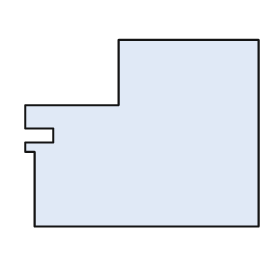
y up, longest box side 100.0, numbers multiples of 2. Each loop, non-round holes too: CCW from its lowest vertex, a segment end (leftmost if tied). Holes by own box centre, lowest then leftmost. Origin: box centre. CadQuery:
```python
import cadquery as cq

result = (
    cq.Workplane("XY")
    .moveTo(-46.0, -40.0)
    .lineTo(50.0, -40.0)
    .lineTo(50.0, 40.0)
    .lineTo(-10.0, 40.0)
    .lineTo(-10.0, 12.0)
    .lineTo(-50.0, 12.0)
    .lineTo(-50.0, 2.0)
    .lineTo(-38.0, 2.0)
    .lineTo(-38.0, -4.0)
    .lineTo(-50.0, -4.0)
    .lineTo(-50.0, -8.0)
    .lineTo(-46.0, -8.0)
    .close()
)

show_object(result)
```